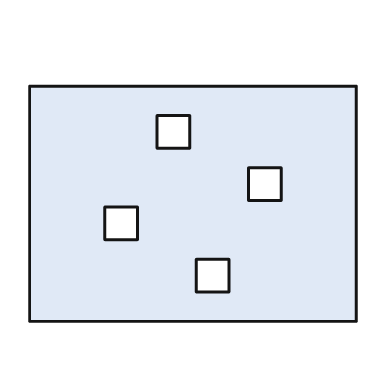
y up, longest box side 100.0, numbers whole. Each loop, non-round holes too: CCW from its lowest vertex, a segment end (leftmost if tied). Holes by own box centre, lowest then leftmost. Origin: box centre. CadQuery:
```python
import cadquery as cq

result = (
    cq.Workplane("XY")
    .moveTo(-50.0, -36.0)
    .lineTo(50.0, -36.0)
    .lineTo(50.0, 36.0)
    .lineTo(-50.0, 36.0)
    .close()
    .moveTo(1.0, -27.0)
    .lineTo(11.0, -27.0)
    .lineTo(11.0, -17.0)
    .lineTo(1.0, -17.0)
    .close()
    .moveTo(-27.0, -11.0)
    .lineTo(-17.0, -11.0)
    .lineTo(-17.0, -1.0)
    .lineTo(-27.0, -1.0)
    .close()
    .moveTo(17.0, 1.0)
    .lineTo(27.0, 1.0)
    .lineTo(27.0, 11.0)
    .lineTo(17.0, 11.0)
    .close()
    .moveTo(-11.0, 17.0)
    .lineTo(-1.0, 17.0)
    .lineTo(-1.0, 27.0)
    .lineTo(-11.0, 27.0)
    .close()
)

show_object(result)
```